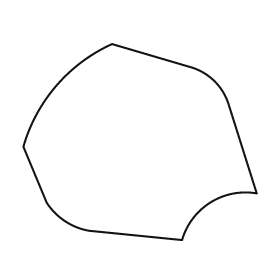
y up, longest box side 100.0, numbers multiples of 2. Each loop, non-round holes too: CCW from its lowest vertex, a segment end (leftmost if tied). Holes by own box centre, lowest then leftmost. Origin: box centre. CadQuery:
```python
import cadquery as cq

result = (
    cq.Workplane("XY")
    .moveTo(18.0, -42.0)
    .threePointArc((30.0, -26.0), (50.0, -22.0))
    .lineTo(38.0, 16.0)
    .threePointArc((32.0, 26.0), (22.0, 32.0))
    .lineTo(-12.0, 42.0)
    .threePointArc((-36.0, 24.0), (-50.0, -2.0))
    .lineTo(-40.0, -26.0)
    .threePointArc((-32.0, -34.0), (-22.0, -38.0))
    .close()
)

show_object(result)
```